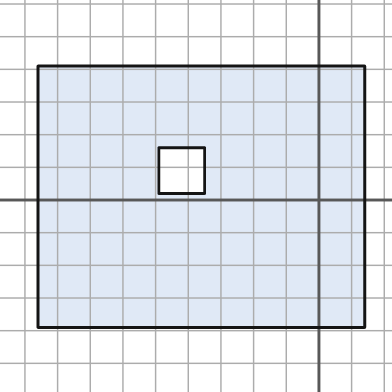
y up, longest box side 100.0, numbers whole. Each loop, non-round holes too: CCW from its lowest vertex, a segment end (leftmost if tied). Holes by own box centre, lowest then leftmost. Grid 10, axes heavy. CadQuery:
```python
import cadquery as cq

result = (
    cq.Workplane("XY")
    .moveTo(-86.0, -39.0)
    .lineTo(14.0, -39.0)
    .lineTo(14.0, 41.0)
    .lineTo(-86.0, 41.0)
    .close()
    .moveTo(-49.0, 2.0)
    .lineTo(-35.0, 2.0)
    .lineTo(-35.0, 16.0)
    .lineTo(-49.0, 16.0)
    .close()
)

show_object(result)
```